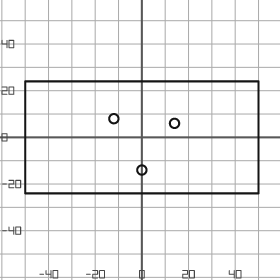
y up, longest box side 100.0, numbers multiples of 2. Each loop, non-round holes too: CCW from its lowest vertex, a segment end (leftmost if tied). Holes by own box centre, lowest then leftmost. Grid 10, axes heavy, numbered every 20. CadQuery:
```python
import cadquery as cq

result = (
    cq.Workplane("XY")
    .moveTo(-50.0, -24.0)
    .lineTo(50.0, -24.0)
    .lineTo(50.0, 24.0)
    .lineTo(-50.0, 24.0)
    .close()
    .moveTo(0.0, -14.0)
    .circle(2.0)
    .moveTo(14.0, 6.0)
    .circle(2.0)
    .moveTo(-12.0, 8.0)
    .circle(2.0)
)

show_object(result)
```